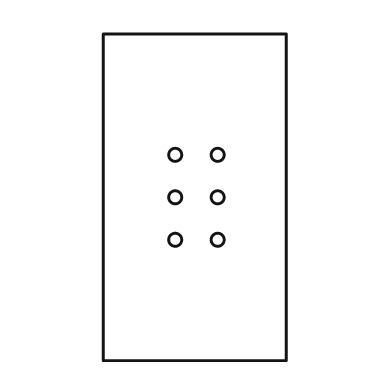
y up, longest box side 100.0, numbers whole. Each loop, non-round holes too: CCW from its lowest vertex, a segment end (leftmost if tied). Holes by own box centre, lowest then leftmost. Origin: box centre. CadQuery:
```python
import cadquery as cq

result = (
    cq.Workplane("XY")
    .moveTo(-28.0, -50.0)
    .lineTo(28.0, -50.0)
    .lineTo(28.0, 50.0)
    .lineTo(-28.0, 50.0)
    .close()
    .moveTo(-6.0, -13.0)
    .circle(2.0)
    .moveTo(7.0, -13.0)
    .circle(2.0)
    .moveTo(-6.0, 0.0)
    .circle(2.0)
    .moveTo(7.0, 0.0)
    .circle(2.0)
    .moveTo(-6.0, 13.0)
    .circle(2.0)
    .moveTo(7.0, 13.0)
    .circle(2.0)
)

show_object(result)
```